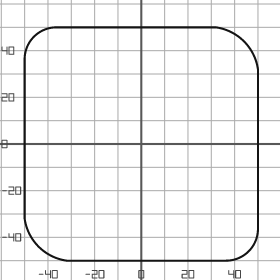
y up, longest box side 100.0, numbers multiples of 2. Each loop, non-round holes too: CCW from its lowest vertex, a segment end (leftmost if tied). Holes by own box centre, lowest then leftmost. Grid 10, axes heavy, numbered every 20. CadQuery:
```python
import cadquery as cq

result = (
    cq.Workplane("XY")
    .moveTo(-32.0, -50.0)
    .lineTo(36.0, -50.0)
    .threePointArc((46.0, -46.0), (50.0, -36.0))
    .lineTo(50.0, 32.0)
    .threePointArc((44.0, 44.0), (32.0, 50.0))
    .lineTo(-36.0, 50.0)
    .threePointArc((-46.0, 46.0), (-50.0, 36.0))
    .lineTo(-50.0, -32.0)
    .threePointArc((-44.0, -44.0), (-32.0, -50.0))
    .close()
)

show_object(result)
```